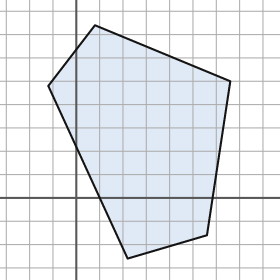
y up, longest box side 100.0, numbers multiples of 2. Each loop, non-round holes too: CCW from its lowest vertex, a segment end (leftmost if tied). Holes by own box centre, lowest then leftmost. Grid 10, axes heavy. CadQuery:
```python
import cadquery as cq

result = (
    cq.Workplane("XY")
    .moveTo(22.0, -26.0)
    .lineTo(56.0, -16.0)
    .lineTo(66.0, 50.0)
    .lineTo(8.0, 74.0)
    .lineTo(-12.0, 48.0)
    .close()
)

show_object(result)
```